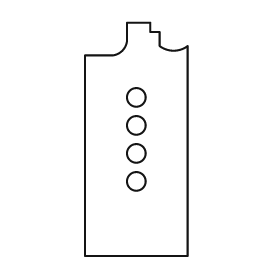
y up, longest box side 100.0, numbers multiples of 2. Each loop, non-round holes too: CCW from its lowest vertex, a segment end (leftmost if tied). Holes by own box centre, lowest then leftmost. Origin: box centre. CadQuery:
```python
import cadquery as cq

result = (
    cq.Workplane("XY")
    .moveTo(-22.0, -50.0)
    .lineTo(22.0, -50.0)
    .lineTo(22.0, 40.0)
    .threePointArc((16.0, 38.0), (10.0, 40.0))
    .lineTo(10.0, 46.0)
    .lineTo(6.0, 46.0)
    .lineTo(6.0, 50.0)
    .lineTo(-4.0, 50.0)
    .lineTo(-4.0, 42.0)
    .threePointArc((-6.0, 38.0), (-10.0, 36.0))
    .lineTo(-22.0, 36.0)
    .close()
    .moveTo(0.0, -18.0)
    .circle(4.0)
    .moveTo(0.0, -6.0)
    .circle(4.0)
    .moveTo(0.0, 6.0)
    .circle(4.0)
    .moveTo(0.0, 18.0)
    .circle(4.0)
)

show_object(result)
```